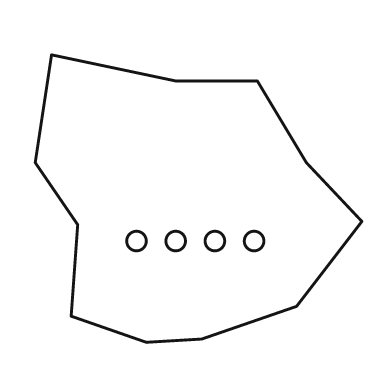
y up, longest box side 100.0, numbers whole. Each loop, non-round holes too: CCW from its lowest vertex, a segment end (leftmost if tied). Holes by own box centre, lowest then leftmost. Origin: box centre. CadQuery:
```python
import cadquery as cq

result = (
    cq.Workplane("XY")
    .moveTo(-16.0, -44.0)
    .lineTo(1.0, -43.0)
    .lineTo(30.0, -33.0)
    .lineTo(50.0, -7.0)
    .lineTo(33.0, 11.0)
    .lineTo(18.0, 36.0)
    .lineTo(-7.0, 36.0)
    .lineTo(-45.0, 44.0)
    .lineTo(-50.0, 11.0)
    .lineTo(-37.0, -8.0)
    .lineTo(-39.0, -36.0)
    .close()
    .moveTo(-19.0, -13.0)
    .circle(3.0)
    .moveTo(-7.0, -13.0)
    .circle(3.0)
    .moveTo(5.0, -13.0)
    .circle(3.0)
    .moveTo(17.0, -13.0)
    .circle(3.0)
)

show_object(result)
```